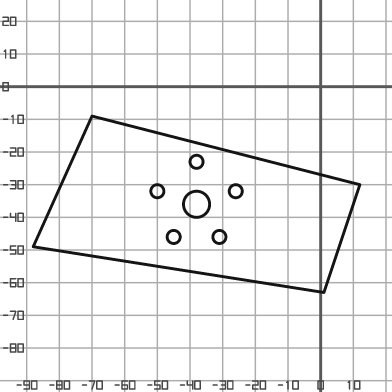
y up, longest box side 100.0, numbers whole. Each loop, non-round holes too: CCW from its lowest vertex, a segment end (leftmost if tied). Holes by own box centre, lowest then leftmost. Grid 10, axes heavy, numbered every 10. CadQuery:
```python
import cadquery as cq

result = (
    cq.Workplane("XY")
    .moveTo(1.0, -63.0)
    .lineTo(12.0, -30.0)
    .lineTo(-70.0, -9.0)
    .lineTo(-88.0, -49.0)
    .close()
    .moveTo(-45.0, -46.0)
    .circle(2.0)
    .moveTo(-31.0, -46.0)
    .circle(2.0)
    .moveTo(-38.0, -36.0)
    .circle(4.0)
    .moveTo(-50.0, -32.0)
    .circle(2.0)
    .moveTo(-26.0, -32.0)
    .circle(2.0)
    .moveTo(-38.0, -23.0)
    .circle(2.0)
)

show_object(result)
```